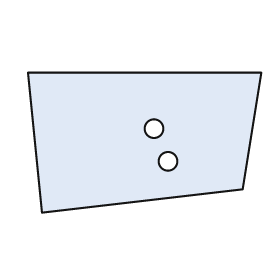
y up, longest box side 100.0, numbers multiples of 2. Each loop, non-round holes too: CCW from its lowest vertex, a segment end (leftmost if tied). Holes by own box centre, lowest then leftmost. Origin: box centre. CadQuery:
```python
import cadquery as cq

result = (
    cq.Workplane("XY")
    .moveTo(-44.0, -30.0)
    .lineTo(42.0, -20.0)
    .lineTo(50.0, 30.0)
    .lineTo(-50.0, 30.0)
    .close()
    .moveTo(10.0, -8.0)
    .circle(4.0)
    .moveTo(4.0, 6.0)
    .circle(4.0)
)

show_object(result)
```